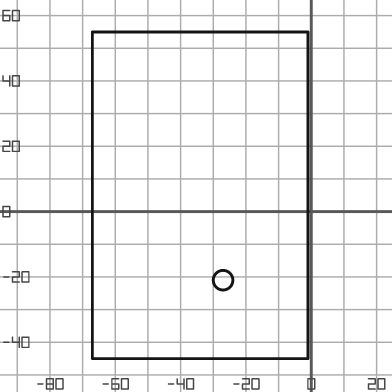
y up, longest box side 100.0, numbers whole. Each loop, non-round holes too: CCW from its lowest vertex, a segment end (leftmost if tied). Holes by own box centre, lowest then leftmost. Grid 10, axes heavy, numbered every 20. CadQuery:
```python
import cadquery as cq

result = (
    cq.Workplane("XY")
    .moveTo(-67.0, -45.0)
    .lineTo(-1.0, -45.0)
    .lineTo(-1.0, 55.0)
    .lineTo(-67.0, 55.0)
    .close()
    .moveTo(-27.0, -21.0)
    .circle(3.0)
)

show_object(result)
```